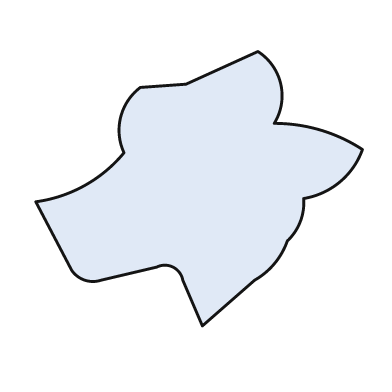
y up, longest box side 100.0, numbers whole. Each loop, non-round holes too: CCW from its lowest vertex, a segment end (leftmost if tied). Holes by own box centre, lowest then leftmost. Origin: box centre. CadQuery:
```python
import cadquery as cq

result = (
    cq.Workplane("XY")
    .moveTo(1.0, -42.0)
    .lineTo(17.0, -28.0)
    .threePointArc((23.0, -23.0), (27.0, -16.0))
    .threePointArc((31.0, -10.0), (32.0, -3.0))
    .threePointArc((43.0, 2.0), (50.0, 12.0))
    .threePointArc((37.0, 18.0), (23.0, 20.0))
    .threePointArc((25.0, 32.0), (18.0, 42.0))
    .lineTo(-4.0, 32.0)
    .lineTo(-18.0, 31.0)
    .threePointArc((-24.0, 22.0), (-23.0, 11.0))
    .threePointArc((-35.0, 1.0), (-50.0, -4.0))
    .lineTo(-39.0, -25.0)
    .threePointArc((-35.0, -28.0), (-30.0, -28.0))
    .lineTo(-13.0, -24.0)
    .threePointArc((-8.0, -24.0), (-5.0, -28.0))
    .close()
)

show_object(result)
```